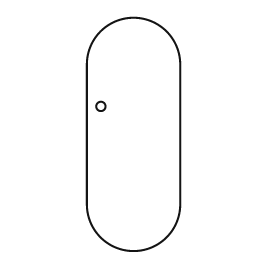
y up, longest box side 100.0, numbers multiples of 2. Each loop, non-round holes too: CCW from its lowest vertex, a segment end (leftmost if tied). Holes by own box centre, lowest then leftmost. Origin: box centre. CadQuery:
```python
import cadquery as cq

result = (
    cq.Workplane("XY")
    .moveTo(-20.0, -30.0)
    .threePointArc((0.0, -50.0), (20.0, -30.0))
    .lineTo(20.0, 30.0)
    .threePointArc((0.0, 50.0), (-20.0, 30.0))
    .close()
    .moveTo(-14.0, 12.0)
    .circle(2.0)
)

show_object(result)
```